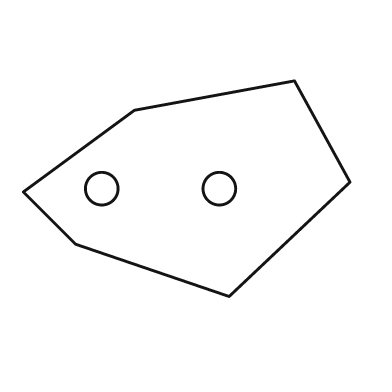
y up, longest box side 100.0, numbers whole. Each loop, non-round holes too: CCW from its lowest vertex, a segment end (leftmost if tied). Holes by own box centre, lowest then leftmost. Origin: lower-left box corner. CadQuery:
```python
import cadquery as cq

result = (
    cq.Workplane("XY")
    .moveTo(63.0, 0.0)
    .lineTo(100.0, 35.0)
    .lineTo(83.0, 66.0)
    .lineTo(34.0, 57.0)
    .lineTo(0.0, 32.0)
    .lineTo(16.0, 16.0)
    .close()
    .moveTo(24.0, 33.0)
    .circle(5.0)
    .moveTo(60.0, 33.0)
    .circle(5.0)
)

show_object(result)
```